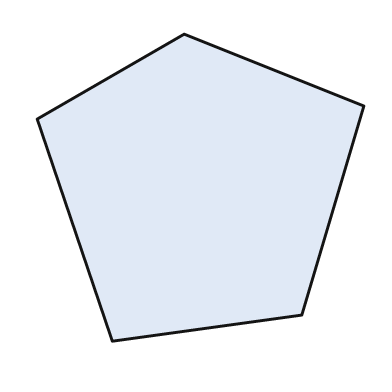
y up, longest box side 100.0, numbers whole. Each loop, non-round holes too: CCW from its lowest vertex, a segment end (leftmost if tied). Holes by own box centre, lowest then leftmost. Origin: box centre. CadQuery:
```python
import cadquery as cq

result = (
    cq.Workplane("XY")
    .moveTo(-27.0, -47.0)
    .lineTo(31.0, -39.0)
    .lineTo(50.0, 25.0)
    .lineTo(-5.0, 47.0)
    .lineTo(-50.0, 21.0)
    .close()
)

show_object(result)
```